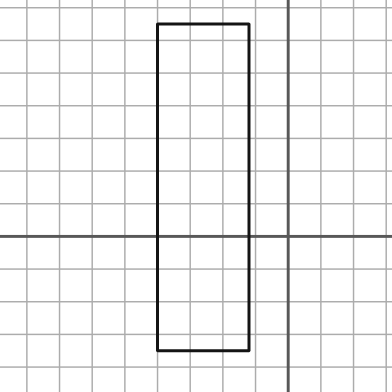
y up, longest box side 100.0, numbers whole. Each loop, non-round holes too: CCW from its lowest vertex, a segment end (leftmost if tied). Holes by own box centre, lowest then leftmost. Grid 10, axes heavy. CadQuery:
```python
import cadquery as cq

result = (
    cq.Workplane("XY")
    .moveTo(-40.0, -35.0)
    .lineTo(-12.0, -35.0)
    .lineTo(-12.0, 65.0)
    .lineTo(-40.0, 65.0)
    .close()
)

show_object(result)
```